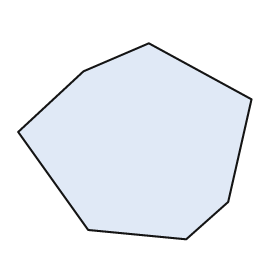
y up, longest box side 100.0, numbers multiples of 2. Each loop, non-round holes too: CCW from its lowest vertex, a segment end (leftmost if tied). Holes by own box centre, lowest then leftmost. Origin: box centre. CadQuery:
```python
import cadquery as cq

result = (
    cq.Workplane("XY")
    .moveTo(22.0, -42.0)
    .lineTo(40.0, -26.0)
    .lineTo(50.0, 18.0)
    .lineTo(6.0, 42.0)
    .lineTo(-22.0, 30.0)
    .lineTo(-50.0, 4.0)
    .lineTo(-20.0, -38.0)
    .close()
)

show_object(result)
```